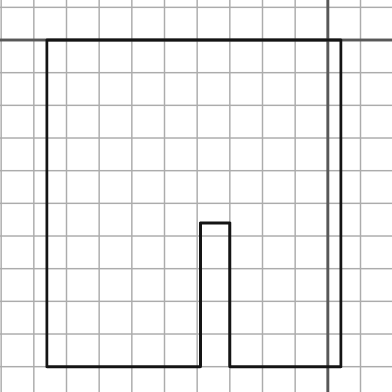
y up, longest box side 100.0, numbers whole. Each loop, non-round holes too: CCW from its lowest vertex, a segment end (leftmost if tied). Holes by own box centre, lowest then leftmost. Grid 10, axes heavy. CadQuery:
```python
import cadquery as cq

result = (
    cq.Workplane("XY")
    .moveTo(-86.0, -100.0)
    .lineTo(-39.0, -100.0)
    .lineTo(-39.0, -56.0)
    .lineTo(-30.0, -56.0)
    .lineTo(-30.0, -100.0)
    .lineTo(4.0, -100.0)
    .lineTo(4.0, 0.0)
    .lineTo(-86.0, 0.0)
    .close()
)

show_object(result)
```